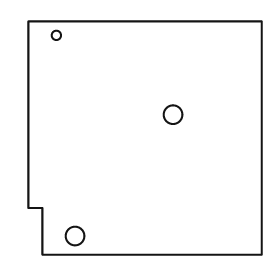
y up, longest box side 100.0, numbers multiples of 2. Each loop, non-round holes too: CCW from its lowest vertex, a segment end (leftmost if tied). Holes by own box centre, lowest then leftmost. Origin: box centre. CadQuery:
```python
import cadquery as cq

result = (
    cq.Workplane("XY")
    .moveTo(-44.0, -50.0)
    .lineTo(50.0, -50.0)
    .lineTo(50.0, 50.0)
    .lineTo(-50.0, 50.0)
    .lineTo(-50.0, -30.0)
    .lineTo(-44.0, -30.0)
    .close()
    .moveTo(-30.0, -42.0)
    .circle(4.0)
    .moveTo(12.0, 10.0)
    .circle(4.0)
    .moveTo(-38.0, 44.0)
    .circle(2.0)
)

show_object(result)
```